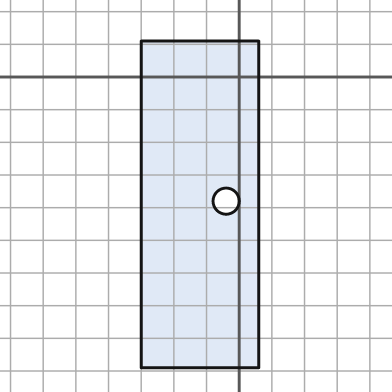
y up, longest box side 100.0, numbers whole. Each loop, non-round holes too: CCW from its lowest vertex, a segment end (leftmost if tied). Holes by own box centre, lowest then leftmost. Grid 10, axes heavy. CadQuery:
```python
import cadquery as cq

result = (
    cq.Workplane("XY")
    .moveTo(-30.0, -89.0)
    .lineTo(6.0, -89.0)
    .lineTo(6.0, 11.0)
    .lineTo(-30.0, 11.0)
    .close()
    .moveTo(-4.0, -38.0)
    .circle(4.0)
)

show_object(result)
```